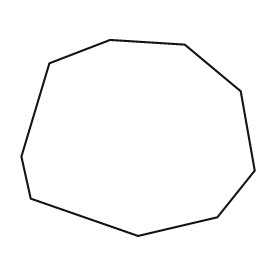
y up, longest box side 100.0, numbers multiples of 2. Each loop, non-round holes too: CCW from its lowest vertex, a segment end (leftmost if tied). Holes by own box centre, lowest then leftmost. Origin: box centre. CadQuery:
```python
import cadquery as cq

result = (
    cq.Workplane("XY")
    .moveTo(0.0, -42.0)
    .lineTo(34.0, -34.0)
    .lineTo(50.0, -14.0)
    .lineTo(44.0, 20.0)
    .lineTo(20.0, 40.0)
    .lineTo(-12.0, 42.0)
    .lineTo(-38.0, 32.0)
    .lineTo(-50.0, -8.0)
    .lineTo(-46.0, -26.0)
    .close()
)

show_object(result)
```